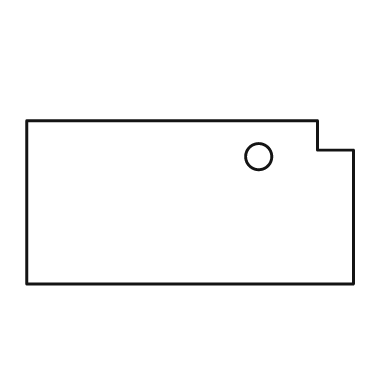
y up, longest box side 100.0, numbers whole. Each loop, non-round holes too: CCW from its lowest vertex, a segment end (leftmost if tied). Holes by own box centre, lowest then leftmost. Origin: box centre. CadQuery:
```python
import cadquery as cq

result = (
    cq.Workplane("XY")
    .moveTo(-50.0, -25.0)
    .lineTo(50.0, -25.0)
    .lineTo(50.0, 16.0)
    .lineTo(39.0, 16.0)
    .lineTo(39.0, 25.0)
    .lineTo(-50.0, 25.0)
    .close()
    .moveTo(21.0, 14.0)
    .circle(4.0)
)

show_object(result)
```